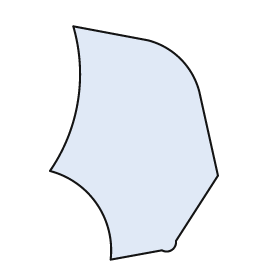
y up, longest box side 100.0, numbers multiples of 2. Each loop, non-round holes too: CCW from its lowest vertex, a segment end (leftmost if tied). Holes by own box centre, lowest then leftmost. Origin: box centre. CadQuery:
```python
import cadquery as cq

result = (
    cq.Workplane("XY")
    .moveTo(-10.0, -50.0)
    .lineTo(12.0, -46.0)
    .threePointArc((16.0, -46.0), (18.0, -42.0))
    .lineTo(36.0, -14.0)
    .lineTo(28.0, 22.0)
    .threePointArc((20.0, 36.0), (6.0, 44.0))
    .lineTo(-26.0, 50.0)
    .threePointArc((-24.0, 18.0), (-36.0, -12.0))
    .threePointArc((-16.0, -26.0), (-10.0, -50.0))
    .close()
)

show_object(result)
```